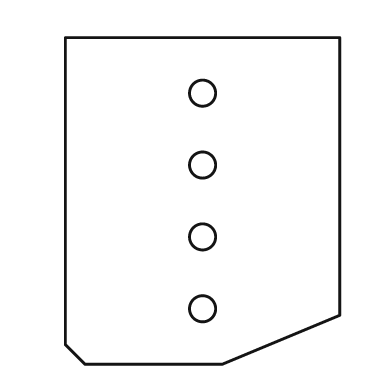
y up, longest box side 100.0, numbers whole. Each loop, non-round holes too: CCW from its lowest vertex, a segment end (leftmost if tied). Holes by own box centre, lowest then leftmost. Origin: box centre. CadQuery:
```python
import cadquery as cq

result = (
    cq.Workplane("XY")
    .moveTo(-36.0, -50.0)
    .lineTo(6.0, -50.0)
    .lineTo(42.0, -35.0)
    .lineTo(42.0, 50.0)
    .lineTo(-42.0, 50.0)
    .lineTo(-42.0, -44.0)
    .close()
    .moveTo(0.0, -33.0)
    .circle(4.0)
    .moveTo(0.0, -11.0)
    .circle(4.0)
    .moveTo(0.0, 11.0)
    .circle(4.0)
    .moveTo(0.0, 33.0)
    .circle(4.0)
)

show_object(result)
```